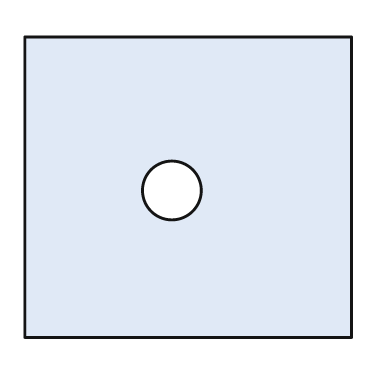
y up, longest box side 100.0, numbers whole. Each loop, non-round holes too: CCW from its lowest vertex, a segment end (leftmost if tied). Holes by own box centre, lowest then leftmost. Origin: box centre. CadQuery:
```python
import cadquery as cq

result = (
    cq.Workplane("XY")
    .moveTo(-50.0, -46.0)
    .lineTo(50.0, -46.0)
    .lineTo(50.0, 46.0)
    .lineTo(-50.0, 46.0)
    .close()
    .moveTo(-5.0, -1.0)
    .circle(9.0)
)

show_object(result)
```